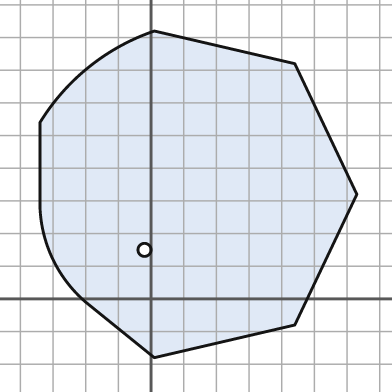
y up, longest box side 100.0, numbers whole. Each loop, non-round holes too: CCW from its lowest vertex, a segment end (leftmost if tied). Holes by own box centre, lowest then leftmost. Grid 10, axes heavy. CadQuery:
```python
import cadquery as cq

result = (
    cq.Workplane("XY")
    .moveTo(1.0, -18.0)
    .lineTo(44.0, -8.0)
    .lineTo(63.0, 32.0)
    .lineTo(44.0, 72.0)
    .lineTo(1.0, 82.0)
    .threePointArc((-19.0, 71.0), (-34.0, 54.0))
    .lineTo(-34.0, 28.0)
    .threePointArc((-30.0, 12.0), (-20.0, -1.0))
    .close()
    .moveTo(-2.0, 15.0)
    .circle(2.0)
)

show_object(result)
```